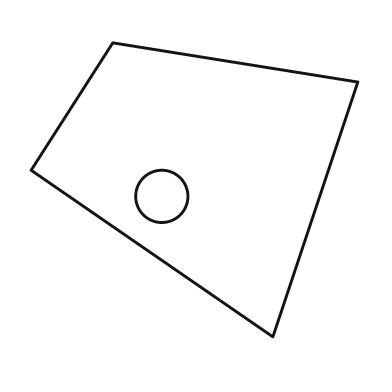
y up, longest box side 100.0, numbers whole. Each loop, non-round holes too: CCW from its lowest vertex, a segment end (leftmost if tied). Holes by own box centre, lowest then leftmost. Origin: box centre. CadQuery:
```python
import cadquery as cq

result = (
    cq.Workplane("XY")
    .moveTo(24.0, -45.0)
    .lineTo(50.0, 33.0)
    .lineTo(-25.0, 45.0)
    .lineTo(-50.0, 6.0)
    .close()
    .moveTo(-10.0, -2.0)
    .circle(8.0)
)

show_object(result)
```